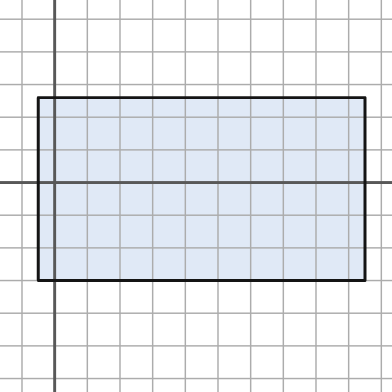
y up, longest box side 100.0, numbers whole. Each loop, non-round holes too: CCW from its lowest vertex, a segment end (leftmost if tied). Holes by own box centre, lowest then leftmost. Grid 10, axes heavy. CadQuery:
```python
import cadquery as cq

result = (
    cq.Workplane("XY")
    .moveTo(-5.0, -30.0)
    .lineTo(95.0, -30.0)
    .lineTo(95.0, 26.0)
    .lineTo(-5.0, 26.0)
    .close()
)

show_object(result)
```